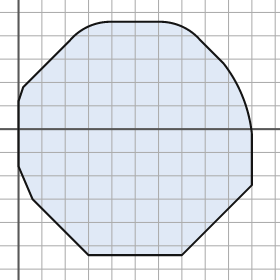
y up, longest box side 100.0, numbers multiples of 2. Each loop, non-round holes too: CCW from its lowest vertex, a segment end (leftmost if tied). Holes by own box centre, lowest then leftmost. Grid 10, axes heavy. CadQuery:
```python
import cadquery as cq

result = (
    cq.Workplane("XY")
    .moveTo(30.0, -54.0)
    .lineTo(70.0, -54.0)
    .lineTo(100.0, -24.0)
    .lineTo(100.0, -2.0)
    .threePointArc((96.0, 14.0), (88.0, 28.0))
    .lineTo(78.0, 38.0)
    .threePointArc((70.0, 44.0), (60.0, 46.0))
    .lineTo(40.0, 46.0)
    .threePointArc((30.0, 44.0), (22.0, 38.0))
    .lineTo(2.0, 18.0)
    .lineTo(0.0, 12.0)
    .lineTo(0.0, -16.0)
    .lineTo(6.0, -30.0)
    .close()
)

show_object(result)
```